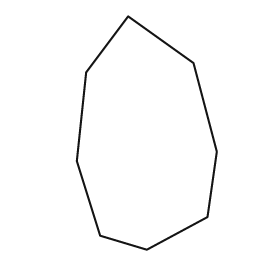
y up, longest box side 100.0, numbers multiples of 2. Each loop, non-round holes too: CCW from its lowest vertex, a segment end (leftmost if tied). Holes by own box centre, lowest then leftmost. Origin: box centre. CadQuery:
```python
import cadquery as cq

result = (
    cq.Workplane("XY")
    .moveTo(0.0, -50.0)
    .lineTo(26.0, -36.0)
    .lineTo(30.0, -8.0)
    .lineTo(20.0, 30.0)
    .lineTo(-8.0, 50.0)
    .lineTo(-26.0, 26.0)
    .lineTo(-30.0, -12.0)
    .lineTo(-20.0, -44.0)
    .close()
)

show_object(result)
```